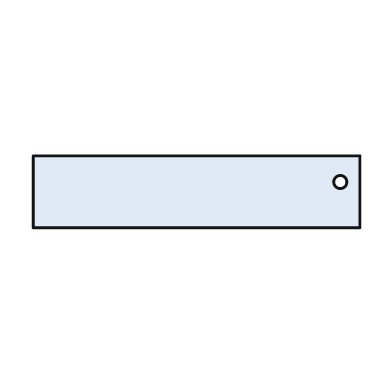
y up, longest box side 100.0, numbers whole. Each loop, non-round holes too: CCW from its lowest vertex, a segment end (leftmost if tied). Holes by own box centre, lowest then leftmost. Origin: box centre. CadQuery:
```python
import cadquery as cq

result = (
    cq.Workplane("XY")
    .moveTo(-50.0, -11.0)
    .lineTo(50.0, -11.0)
    .lineTo(50.0, 11.0)
    .lineTo(-50.0, 11.0)
    .close()
    .moveTo(44.0, 3.0)
    .circle(2.0)
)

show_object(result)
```